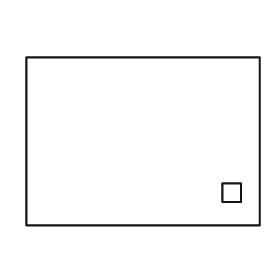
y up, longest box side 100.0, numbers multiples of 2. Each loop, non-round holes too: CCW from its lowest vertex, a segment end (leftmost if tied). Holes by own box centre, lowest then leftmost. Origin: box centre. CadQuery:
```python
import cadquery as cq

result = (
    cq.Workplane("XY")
    .moveTo(-50.0, -36.0)
    .lineTo(50.0, -36.0)
    .lineTo(50.0, 36.0)
    .lineTo(-50.0, 36.0)
    .close()
    .moveTo(34.0, -26.0)
    .lineTo(42.0, -26.0)
    .lineTo(42.0, -18.0)
    .lineTo(34.0, -18.0)
    .close()
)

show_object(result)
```